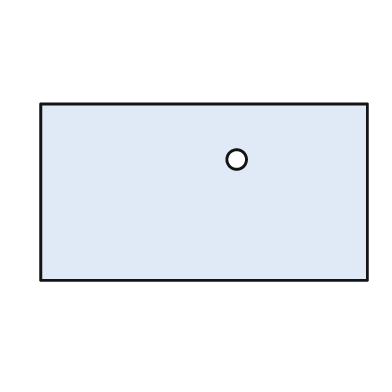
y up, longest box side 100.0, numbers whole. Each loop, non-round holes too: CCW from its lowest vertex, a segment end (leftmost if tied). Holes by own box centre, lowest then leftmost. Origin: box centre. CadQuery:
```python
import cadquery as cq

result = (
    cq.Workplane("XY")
    .moveTo(-50.0, -27.0)
    .lineTo(50.0, -27.0)
    .lineTo(50.0, 27.0)
    .lineTo(-50.0, 27.0)
    .close()
    .moveTo(10.0, 10.0)
    .circle(3.0)
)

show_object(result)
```